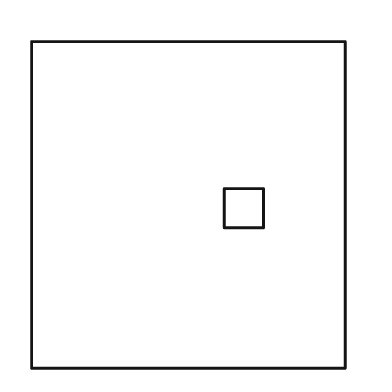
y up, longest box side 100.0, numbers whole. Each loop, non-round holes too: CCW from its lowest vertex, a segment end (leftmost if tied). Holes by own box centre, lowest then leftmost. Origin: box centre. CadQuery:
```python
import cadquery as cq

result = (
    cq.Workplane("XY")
    .moveTo(-48.0, -50.0)
    .lineTo(48.0, -50.0)
    .lineTo(48.0, 50.0)
    .lineTo(-48.0, 50.0)
    .close()
    .moveTo(11.0, -7.0)
    .lineTo(23.0, -7.0)
    .lineTo(23.0, 5.0)
    .lineTo(11.0, 5.0)
    .close()
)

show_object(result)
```